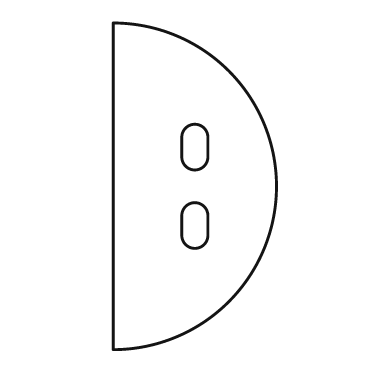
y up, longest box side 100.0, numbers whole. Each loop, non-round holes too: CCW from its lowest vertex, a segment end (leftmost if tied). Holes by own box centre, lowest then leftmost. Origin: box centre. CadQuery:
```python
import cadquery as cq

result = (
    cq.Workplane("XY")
    .moveTo(-25.0, -50.0)
    .threePointArc((25.0, 0.0), (-25.0, 50.0))
    .close()
    .moveTo(-4.0, -15.0)
    .threePointArc((0.0, -19.0), (4.0, -15.0))
    .lineTo(4.0, -9.0)
    .threePointArc((0.0, -5.0), (-4.0, -9.0))
    .close()
    .moveTo(-4.0, 9.0)
    .threePointArc((0.0, 5.0), (4.0, 9.0))
    .lineTo(4.0, 15.0)
    .threePointArc((0.0, 19.0), (-4.0, 15.0))
    .close()
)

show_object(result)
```